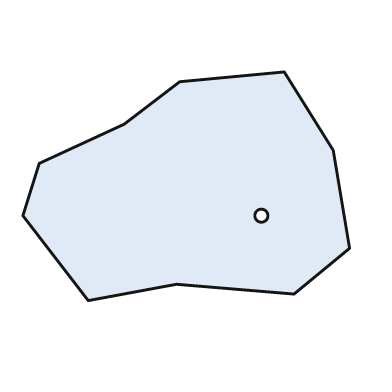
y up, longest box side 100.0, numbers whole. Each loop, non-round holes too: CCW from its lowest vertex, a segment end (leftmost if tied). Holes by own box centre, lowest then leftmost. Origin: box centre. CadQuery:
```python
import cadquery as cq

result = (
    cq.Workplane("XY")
    .moveTo(-30.0, -35.0)
    .lineTo(-3.0, -30.0)
    .lineTo(33.0, -33.0)
    .lineTo(50.0, -19.0)
    .lineTo(45.0, 11.0)
    .lineTo(30.0, 35.0)
    .lineTo(-2.0, 32.0)
    .lineTo(-19.0, 19.0)
    .lineTo(-45.0, 7.0)
    .lineTo(-50.0, -9.0)
    .close()
    .moveTo(23.0, -9.0)
    .circle(2.0)
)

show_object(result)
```